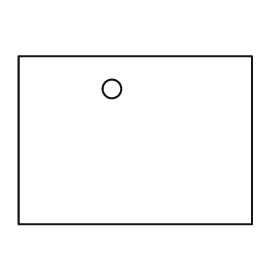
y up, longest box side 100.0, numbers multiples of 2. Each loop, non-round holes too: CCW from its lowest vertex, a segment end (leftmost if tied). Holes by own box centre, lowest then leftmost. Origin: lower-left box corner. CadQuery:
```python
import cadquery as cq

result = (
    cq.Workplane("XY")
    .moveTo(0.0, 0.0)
    .lineTo(100.0, 0.0)
    .lineTo(100.0, 72.0)
    .lineTo(0.0, 72.0)
    .close()
    .moveTo(40.0, 58.0)
    .circle(4.0)
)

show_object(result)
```